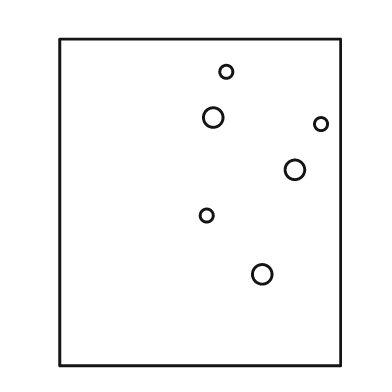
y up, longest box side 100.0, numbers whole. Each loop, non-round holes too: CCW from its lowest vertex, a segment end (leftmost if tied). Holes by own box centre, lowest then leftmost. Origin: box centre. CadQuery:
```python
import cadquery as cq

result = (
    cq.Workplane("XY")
    .moveTo(-43.0, -50.0)
    .lineTo(43.0, -50.0)
    .lineTo(43.0, 50.0)
    .lineTo(-43.0, 50.0)
    .close()
    .moveTo(19.0, -22.0)
    .circle(3.0)
    .moveTo(2.0, -4.0)
    .circle(2.0)
    .moveTo(29.0, 10.0)
    .circle(3.0)
    .moveTo(37.0, 24.0)
    .circle(2.0)
    .moveTo(4.0, 26.0)
    .circle(3.0)
    .moveTo(8.0, 40.0)
    .circle(2.0)
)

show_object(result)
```